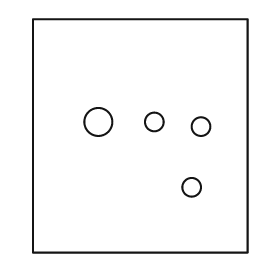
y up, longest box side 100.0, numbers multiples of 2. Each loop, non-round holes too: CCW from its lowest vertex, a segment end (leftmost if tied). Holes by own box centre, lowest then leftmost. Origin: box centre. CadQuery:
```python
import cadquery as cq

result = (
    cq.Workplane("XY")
    .moveTo(-46.0, -50.0)
    .lineTo(46.0, -50.0)
    .lineTo(46.0, 50.0)
    .lineTo(-46.0, 50.0)
    .close()
    .moveTo(22.0, -22.0)
    .circle(4.0)
    .moveTo(26.0, 4.0)
    .circle(4.0)
    .moveTo(-18.0, 6.0)
    .circle(6.0)
    .moveTo(6.0, 6.0)
    .circle(4.0)
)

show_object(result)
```